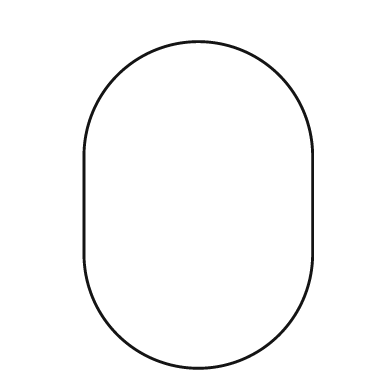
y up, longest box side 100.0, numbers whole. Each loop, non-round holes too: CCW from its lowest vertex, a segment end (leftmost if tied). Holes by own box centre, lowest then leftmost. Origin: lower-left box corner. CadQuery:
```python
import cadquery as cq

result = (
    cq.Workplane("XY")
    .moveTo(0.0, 35.0)
    .threePointArc((35.0, 0.0), (70.0, 35.0))
    .lineTo(70.0, 65.0)
    .threePointArc((35.0, 100.0), (0.0, 65.0))
    .close()
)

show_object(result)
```